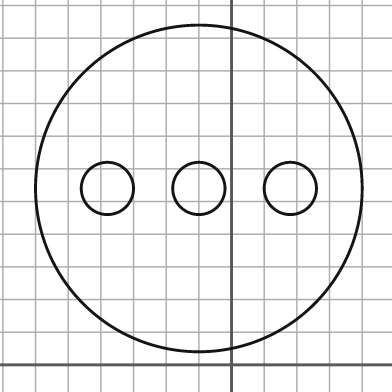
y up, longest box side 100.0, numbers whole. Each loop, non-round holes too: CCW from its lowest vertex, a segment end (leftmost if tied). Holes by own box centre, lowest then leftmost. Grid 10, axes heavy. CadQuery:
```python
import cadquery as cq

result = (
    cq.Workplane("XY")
    .moveTo(-10.0, 54.0)
    .circle(50.0)
    .moveTo(-38.0, 54.0)
    .circle(8.0)
    .moveTo(-10.0, 54.0)
    .circle(8.0)
    .moveTo(18.0, 54.0)
    .circle(8.0)
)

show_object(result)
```